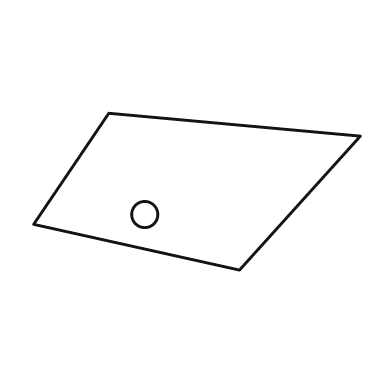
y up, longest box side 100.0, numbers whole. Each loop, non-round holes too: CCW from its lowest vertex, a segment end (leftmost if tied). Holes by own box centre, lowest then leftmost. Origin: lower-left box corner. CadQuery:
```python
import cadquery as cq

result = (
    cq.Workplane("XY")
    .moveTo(63.0, 0.0)
    .lineTo(100.0, 41.0)
    .lineTo(23.0, 48.0)
    .lineTo(0.0, 14.0)
    .close()
    .moveTo(34.0, 17.0)
    .circle(4.0)
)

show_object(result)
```